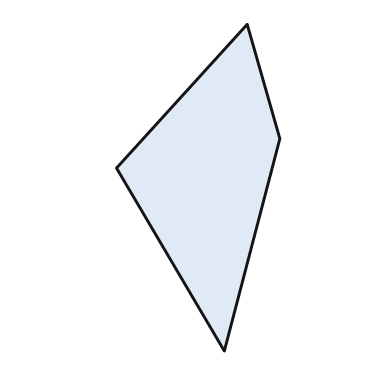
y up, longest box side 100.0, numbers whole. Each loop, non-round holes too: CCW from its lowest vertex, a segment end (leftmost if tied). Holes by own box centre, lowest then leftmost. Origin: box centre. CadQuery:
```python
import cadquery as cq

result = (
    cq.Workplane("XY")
    .moveTo(8.0, -50.0)
    .lineTo(25.0, 15.0)
    .lineTo(15.0, 50.0)
    .lineTo(-25.0, 6.0)
    .close()
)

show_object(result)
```